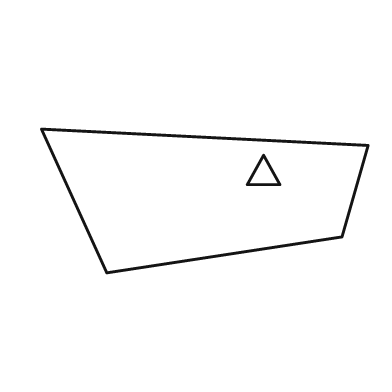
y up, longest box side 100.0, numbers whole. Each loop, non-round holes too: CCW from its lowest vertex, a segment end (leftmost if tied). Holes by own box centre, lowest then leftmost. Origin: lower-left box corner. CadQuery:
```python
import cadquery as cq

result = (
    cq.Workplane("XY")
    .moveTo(20.0, 0.0)
    .lineTo(92.0, 11.0)
    .lineTo(100.0, 39.0)
    .lineTo(0.0, 44.0)
    .close()
    .moveTo(63.0, 27.0)
    .lineTo(73.0, 27.0)
    .lineTo(68.0, 36.0)
    .close()
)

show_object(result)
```